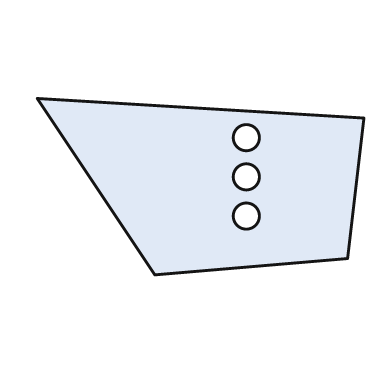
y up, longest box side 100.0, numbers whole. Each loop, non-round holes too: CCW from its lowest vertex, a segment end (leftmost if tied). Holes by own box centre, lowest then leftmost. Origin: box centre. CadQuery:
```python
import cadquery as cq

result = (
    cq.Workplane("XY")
    .moveTo(-14.0, -27.0)
    .lineTo(45.0, -22.0)
    .lineTo(50.0, 21.0)
    .lineTo(-50.0, 27.0)
    .close()
    .moveTo(14.0, -9.0)
    .circle(4.0)
    .moveTo(14.0, 3.0)
    .circle(4.0)
    .moveTo(14.0, 15.0)
    .circle(4.0)
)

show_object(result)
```